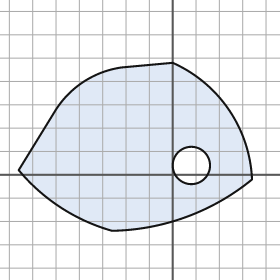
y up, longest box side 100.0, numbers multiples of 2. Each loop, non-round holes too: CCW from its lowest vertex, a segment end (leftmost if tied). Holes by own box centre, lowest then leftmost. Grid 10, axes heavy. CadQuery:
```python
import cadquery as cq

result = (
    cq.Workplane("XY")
    .moveTo(-26.0, -24.0)
    .threePointArc((6.0, -18.0), (34.0, -2.0))
    .threePointArc((24.0, 28.0), (0.0, 48.0))
    .lineTo(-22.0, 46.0)
    .threePointArc((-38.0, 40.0), (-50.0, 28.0))
    .lineTo(-66.0, 2.0)
    .threePointArc((-48.0, -14.0), (-26.0, -24.0))
    .close()
    .moveTo(8.0, 4.0)
    .circle(8.0)
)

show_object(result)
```